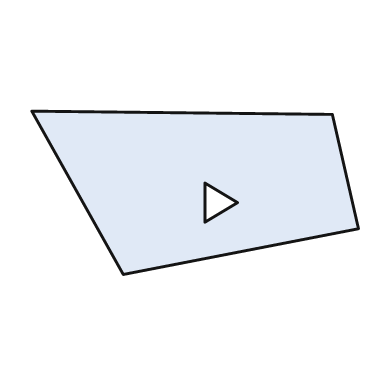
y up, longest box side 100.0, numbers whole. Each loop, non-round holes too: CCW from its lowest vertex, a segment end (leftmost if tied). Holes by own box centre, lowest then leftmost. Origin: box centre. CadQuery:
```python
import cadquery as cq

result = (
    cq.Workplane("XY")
    .moveTo(-22.0, -25.0)
    .lineTo(50.0, -11.0)
    .lineTo(42.0, 24.0)
    .lineTo(-50.0, 25.0)
    .close()
    .moveTo(3.0, -9.0)
    .lineTo(13.0, -3.0)
    .lineTo(3.0, 3.0)
    .close()
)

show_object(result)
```